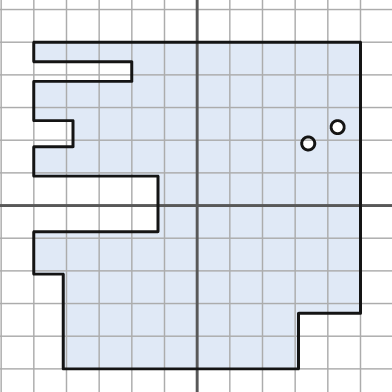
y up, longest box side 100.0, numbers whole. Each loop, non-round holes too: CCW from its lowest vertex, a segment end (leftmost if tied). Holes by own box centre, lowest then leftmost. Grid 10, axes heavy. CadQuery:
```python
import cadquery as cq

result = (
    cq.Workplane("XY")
    .moveTo(-41.0, -50.0)
    .lineTo(31.0, -50.0)
    .lineTo(31.0, -33.0)
    .lineTo(50.0, -33.0)
    .lineTo(50.0, 50.0)
    .lineTo(-50.0, 50.0)
    .lineTo(-50.0, 44.0)
    .lineTo(-20.0, 44.0)
    .lineTo(-20.0, 38.0)
    .lineTo(-50.0, 38.0)
    .lineTo(-50.0, 26.0)
    .lineTo(-38.0, 26.0)
    .lineTo(-38.0, 18.0)
    .lineTo(-50.0, 18.0)
    .lineTo(-50.0, 9.0)
    .lineTo(-12.0, 9.0)
    .lineTo(-12.0, -8.0)
    .lineTo(-50.0, -8.0)
    .lineTo(-50.0, -21.0)
    .lineTo(-41.0, -21.0)
    .close()
    .moveTo(34.0, 19.0)
    .circle(2.0)
    .moveTo(43.0, 24.0)
    .circle(2.0)
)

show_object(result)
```